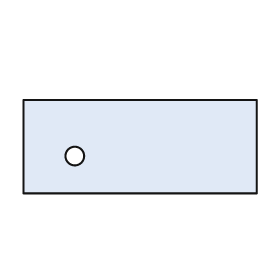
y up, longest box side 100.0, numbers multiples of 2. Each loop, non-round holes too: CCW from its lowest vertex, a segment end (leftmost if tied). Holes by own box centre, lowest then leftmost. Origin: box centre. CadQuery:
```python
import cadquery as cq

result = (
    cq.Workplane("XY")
    .moveTo(-50.0, -20.0)
    .lineTo(50.0, -20.0)
    .lineTo(50.0, 20.0)
    .lineTo(-50.0, 20.0)
    .close()
    .moveTo(-28.0, -4.0)
    .circle(4.0)
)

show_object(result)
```